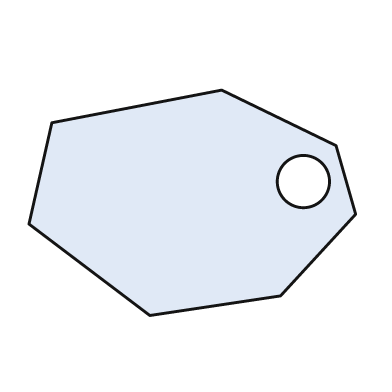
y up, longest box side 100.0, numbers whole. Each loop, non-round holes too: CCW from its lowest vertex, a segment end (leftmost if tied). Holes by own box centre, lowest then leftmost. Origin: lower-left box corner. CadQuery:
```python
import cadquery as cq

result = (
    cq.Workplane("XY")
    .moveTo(37.0, 0.0)
    .lineTo(77.0, 6.0)
    .lineTo(100.0, 31.0)
    .lineTo(94.0, 52.0)
    .lineTo(59.0, 69.0)
    .lineTo(7.0, 59.0)
    .lineTo(0.0, 28.0)
    .close()
    .moveTo(84.0, 41.0)
    .circle(8.0)
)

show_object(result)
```